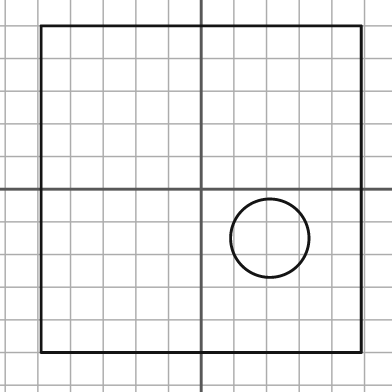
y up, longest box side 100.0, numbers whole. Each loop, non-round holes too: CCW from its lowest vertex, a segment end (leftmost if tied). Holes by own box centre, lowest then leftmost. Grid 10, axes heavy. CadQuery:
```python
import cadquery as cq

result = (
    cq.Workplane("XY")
    .moveTo(-49.0, -50.0)
    .lineTo(49.0, -50.0)
    .lineTo(49.0, 50.0)
    .lineTo(-49.0, 50.0)
    .close()
    .moveTo(21.0, -15.0)
    .circle(12.0)
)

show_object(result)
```